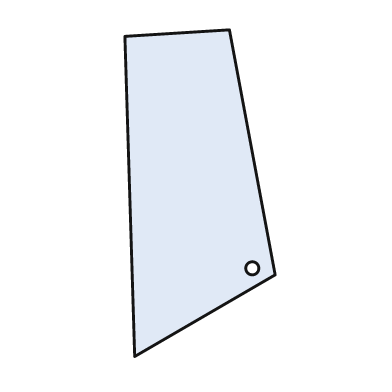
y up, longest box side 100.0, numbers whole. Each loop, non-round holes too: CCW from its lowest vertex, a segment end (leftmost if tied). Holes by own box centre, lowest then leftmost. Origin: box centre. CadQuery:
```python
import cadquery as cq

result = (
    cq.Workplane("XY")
    .moveTo(-20.0, -50.0)
    .lineTo(23.0, -25.0)
    .lineTo(9.0, 50.0)
    .lineTo(-23.0, 48.0)
    .close()
    .moveTo(16.0, -23.0)
    .circle(2.0)
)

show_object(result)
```